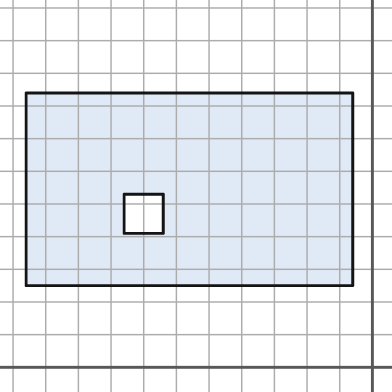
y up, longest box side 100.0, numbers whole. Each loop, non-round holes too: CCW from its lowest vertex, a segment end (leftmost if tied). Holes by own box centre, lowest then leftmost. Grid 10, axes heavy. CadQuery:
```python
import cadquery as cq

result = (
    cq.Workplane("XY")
    .moveTo(-106.0, 25.0)
    .lineTo(-6.0, 25.0)
    .lineTo(-6.0, 84.0)
    .lineTo(-106.0, 84.0)
    .close()
    .moveTo(-76.0, 41.0)
    .lineTo(-64.0, 41.0)
    .lineTo(-64.0, 53.0)
    .lineTo(-76.0, 53.0)
    .close()
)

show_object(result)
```